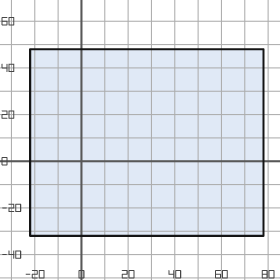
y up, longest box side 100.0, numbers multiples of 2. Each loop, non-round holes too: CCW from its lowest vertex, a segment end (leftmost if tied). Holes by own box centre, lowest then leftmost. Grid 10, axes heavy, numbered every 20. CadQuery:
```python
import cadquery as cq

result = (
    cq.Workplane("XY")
    .moveTo(-22.0, -32.0)
    .lineTo(78.0, -32.0)
    .lineTo(78.0, 48.0)
    .lineTo(-22.0, 48.0)
    .close()
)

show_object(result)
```